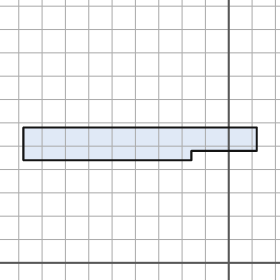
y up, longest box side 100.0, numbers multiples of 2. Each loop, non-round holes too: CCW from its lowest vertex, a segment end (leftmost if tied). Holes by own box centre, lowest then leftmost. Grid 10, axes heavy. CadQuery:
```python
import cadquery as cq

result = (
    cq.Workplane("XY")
    .moveTo(-88.0, 44.0)
    .lineTo(-16.0, 44.0)
    .lineTo(-16.0, 48.0)
    .lineTo(12.0, 48.0)
    .lineTo(12.0, 58.0)
    .lineTo(-88.0, 58.0)
    .close()
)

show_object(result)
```